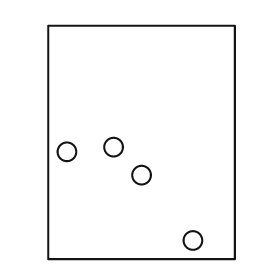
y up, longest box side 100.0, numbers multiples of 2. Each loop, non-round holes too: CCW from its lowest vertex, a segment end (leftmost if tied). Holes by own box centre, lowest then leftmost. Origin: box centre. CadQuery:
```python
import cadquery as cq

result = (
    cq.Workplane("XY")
    .moveTo(-40.0, -50.0)
    .lineTo(40.0, -50.0)
    .lineTo(40.0, 50.0)
    .lineTo(-40.0, 50.0)
    .close()
    .moveTo(22.0, -42.0)
    .circle(4.0)
    .moveTo(0.0, -14.0)
    .circle(4.0)
    .moveTo(-32.0, -4.0)
    .circle(4.0)
    .moveTo(-12.0, -2.0)
    .circle(4.0)
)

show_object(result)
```